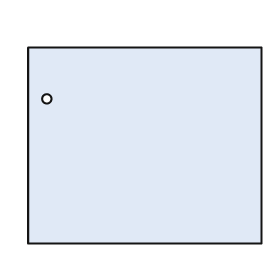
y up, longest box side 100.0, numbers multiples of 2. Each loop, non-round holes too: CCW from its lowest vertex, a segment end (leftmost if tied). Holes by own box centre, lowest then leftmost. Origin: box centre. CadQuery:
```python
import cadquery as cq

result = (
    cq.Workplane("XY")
    .moveTo(-50.0, -42.0)
    .lineTo(50.0, -42.0)
    .lineTo(50.0, 42.0)
    .lineTo(-50.0, 42.0)
    .close()
    .moveTo(-42.0, 20.0)
    .circle(2.0)
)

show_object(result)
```